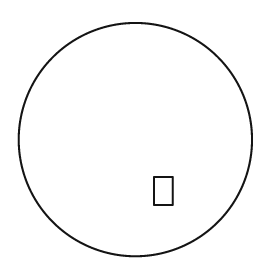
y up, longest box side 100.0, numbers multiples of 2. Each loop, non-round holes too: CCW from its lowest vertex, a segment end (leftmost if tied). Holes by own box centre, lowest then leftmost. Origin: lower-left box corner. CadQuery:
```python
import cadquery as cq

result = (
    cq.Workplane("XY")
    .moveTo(50.0, 50.0)
    .circle(50.0)
    .moveTo(58.0, 22.0)
    .lineTo(66.0, 22.0)
    .lineTo(66.0, 34.0)
    .lineTo(58.0, 34.0)
    .close()
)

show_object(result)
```